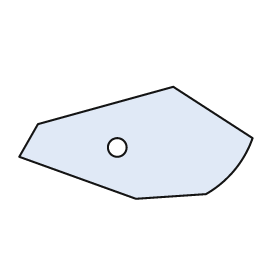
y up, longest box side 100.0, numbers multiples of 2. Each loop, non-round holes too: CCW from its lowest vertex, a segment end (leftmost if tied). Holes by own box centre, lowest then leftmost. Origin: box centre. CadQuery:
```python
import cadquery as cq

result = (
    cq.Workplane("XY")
    .moveTo(0.0, -24.0)
    .lineTo(30.0, -22.0)
    .threePointArc((42.0, -12.0), (50.0, 2.0))
    .lineTo(16.0, 24.0)
    .lineTo(-42.0, 8.0)
    .lineTo(-50.0, -6.0)
    .close()
    .moveTo(-8.0, -2.0)
    .circle(4.0)
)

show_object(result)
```